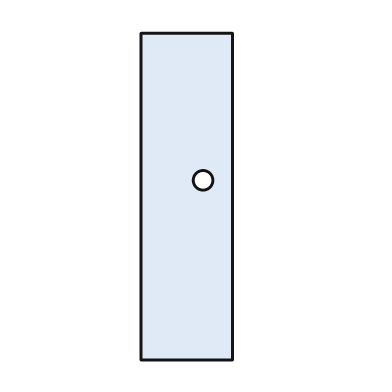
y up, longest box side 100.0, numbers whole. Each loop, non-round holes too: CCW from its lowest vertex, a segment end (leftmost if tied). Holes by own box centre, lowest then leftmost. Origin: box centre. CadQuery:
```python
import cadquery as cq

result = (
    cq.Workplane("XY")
    .moveTo(-14.0, -50.0)
    .lineTo(14.0, -50.0)
    .lineTo(14.0, 50.0)
    .lineTo(-14.0, 50.0)
    .close()
    .moveTo(5.0, 5.0)
    .circle(3.0)
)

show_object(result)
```